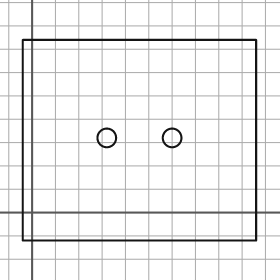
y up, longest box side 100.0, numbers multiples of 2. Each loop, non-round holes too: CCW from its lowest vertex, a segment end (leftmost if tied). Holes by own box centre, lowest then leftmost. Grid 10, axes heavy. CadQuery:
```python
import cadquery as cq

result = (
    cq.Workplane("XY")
    .moveTo(-4.0, -12.0)
    .lineTo(96.0, -12.0)
    .lineTo(96.0, 74.0)
    .lineTo(-4.0, 74.0)
    .close()
    .moveTo(32.0, 32.0)
    .circle(4.0)
    .moveTo(60.0, 32.0)
    .circle(4.0)
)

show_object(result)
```